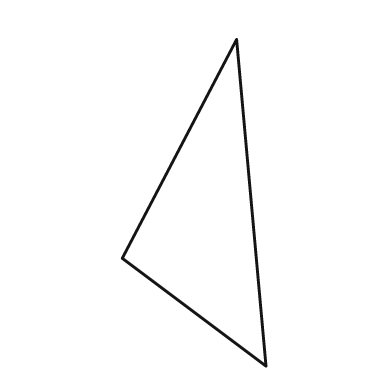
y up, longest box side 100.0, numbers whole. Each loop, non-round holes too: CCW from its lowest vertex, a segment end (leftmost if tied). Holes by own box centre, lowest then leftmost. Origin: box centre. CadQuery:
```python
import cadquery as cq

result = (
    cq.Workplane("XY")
    .moveTo(22.0, -50.0)
    .lineTo(13.0, 50.0)
    .lineTo(-22.0, -17.0)
    .close()
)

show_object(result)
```